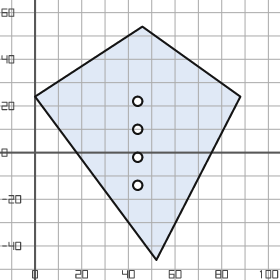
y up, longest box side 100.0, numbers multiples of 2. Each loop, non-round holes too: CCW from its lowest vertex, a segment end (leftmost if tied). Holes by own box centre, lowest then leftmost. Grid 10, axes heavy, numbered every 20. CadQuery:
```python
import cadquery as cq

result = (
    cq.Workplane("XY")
    .moveTo(52.0, -46.0)
    .lineTo(88.0, 24.0)
    .lineTo(46.0, 54.0)
    .lineTo(0.0, 24.0)
    .close()
    .moveTo(44.0, -14.0)
    .circle(2.0)
    .moveTo(44.0, -2.0)
    .circle(2.0)
    .moveTo(44.0, 10.0)
    .circle(2.0)
    .moveTo(44.0, 22.0)
    .circle(2.0)
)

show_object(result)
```